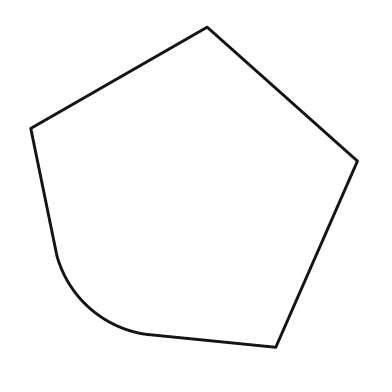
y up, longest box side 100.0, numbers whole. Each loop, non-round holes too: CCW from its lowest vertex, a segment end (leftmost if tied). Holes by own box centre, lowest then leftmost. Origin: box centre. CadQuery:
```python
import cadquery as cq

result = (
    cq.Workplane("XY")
    .moveTo(25.0, -49.0)
    .lineTo(50.0, 8.0)
    .lineTo(4.0, 49.0)
    .lineTo(-50.0, 18.0)
    .lineTo(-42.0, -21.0)
    .threePointArc((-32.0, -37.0), (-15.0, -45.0))
    .close()
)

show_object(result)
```